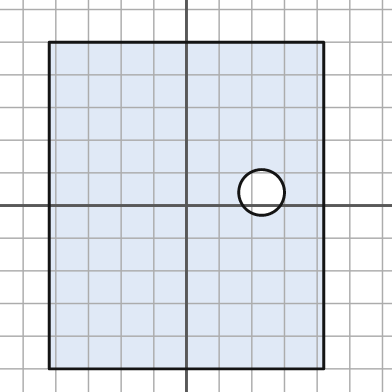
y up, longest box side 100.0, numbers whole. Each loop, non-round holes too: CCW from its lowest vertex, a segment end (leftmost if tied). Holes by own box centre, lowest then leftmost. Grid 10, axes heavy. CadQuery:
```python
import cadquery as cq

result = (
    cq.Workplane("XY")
    .moveTo(-42.0, -50.0)
    .lineTo(42.0, -50.0)
    .lineTo(42.0, 50.0)
    .lineTo(-42.0, 50.0)
    .close()
    .moveTo(23.0, 4.0)
    .circle(7.0)
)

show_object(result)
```